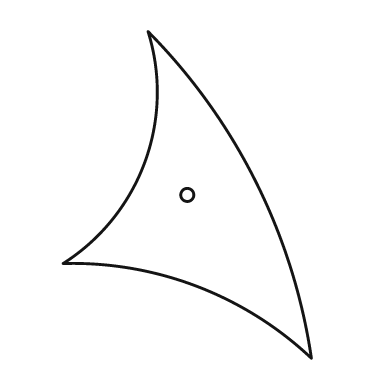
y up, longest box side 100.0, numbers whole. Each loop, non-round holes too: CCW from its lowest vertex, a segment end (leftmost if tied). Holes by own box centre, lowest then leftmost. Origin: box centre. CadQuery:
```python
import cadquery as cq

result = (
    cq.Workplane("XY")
    .moveTo(38.0, -50.0)
    .threePointArc((21.0, 4.0), (-12.0, 50.0))
    .threePointArc((-13.0, 10.0), (-38.0, -21.0))
    .threePointArc((3.0, -28.0), (38.0, -50.0))
    .close()
    .moveTo(0.0, 0.0)
    .circle(2.0)
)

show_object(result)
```